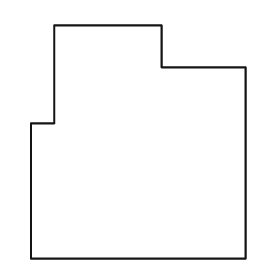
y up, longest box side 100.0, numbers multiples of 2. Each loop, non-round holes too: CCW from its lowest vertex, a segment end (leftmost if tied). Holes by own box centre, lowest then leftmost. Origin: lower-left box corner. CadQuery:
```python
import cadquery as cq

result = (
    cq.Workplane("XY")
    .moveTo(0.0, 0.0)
    .lineTo(92.0, 0.0)
    .lineTo(92.0, 82.0)
    .lineTo(56.0, 82.0)
    .lineTo(56.0, 100.0)
    .lineTo(10.0, 100.0)
    .lineTo(10.0, 58.0)
    .lineTo(0.0, 58.0)
    .close()
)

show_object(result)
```